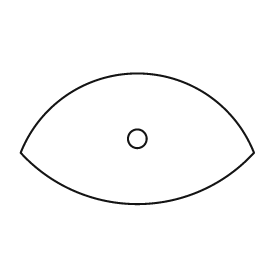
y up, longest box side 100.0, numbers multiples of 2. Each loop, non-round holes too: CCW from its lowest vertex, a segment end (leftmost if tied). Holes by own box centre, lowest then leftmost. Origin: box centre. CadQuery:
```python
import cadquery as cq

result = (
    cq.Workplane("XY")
    .moveTo(-50.0, -6.0)
    .threePointArc((0.0, -28.0), (50.0, -6.0))
    .threePointArc((0.0, 28.0), (-50.0, -6.0))
    .close()
    .moveTo(0.0, 0.0)
    .circle(4.0)
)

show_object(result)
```